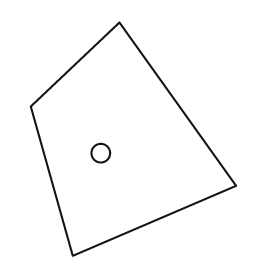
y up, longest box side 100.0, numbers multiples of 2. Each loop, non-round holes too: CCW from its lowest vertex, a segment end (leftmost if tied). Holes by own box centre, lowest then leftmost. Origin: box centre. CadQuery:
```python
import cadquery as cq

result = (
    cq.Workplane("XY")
    .moveTo(-26.0, -50.0)
    .lineTo(44.0, -20.0)
    .lineTo(-6.0, 50.0)
    .lineTo(-44.0, 14.0)
    .close()
    .moveTo(-14.0, -6.0)
    .circle(4.0)
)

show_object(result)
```